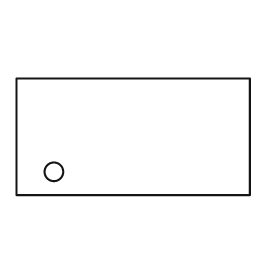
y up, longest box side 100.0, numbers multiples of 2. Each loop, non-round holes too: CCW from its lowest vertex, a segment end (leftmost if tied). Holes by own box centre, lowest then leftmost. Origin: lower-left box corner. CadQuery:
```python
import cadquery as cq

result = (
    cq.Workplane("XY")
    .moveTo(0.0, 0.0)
    .lineTo(100.0, 0.0)
    .lineTo(100.0, 50.0)
    .lineTo(0.0, 50.0)
    .close()
    .moveTo(16.0, 10.0)
    .circle(4.0)
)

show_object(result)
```